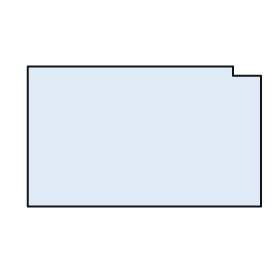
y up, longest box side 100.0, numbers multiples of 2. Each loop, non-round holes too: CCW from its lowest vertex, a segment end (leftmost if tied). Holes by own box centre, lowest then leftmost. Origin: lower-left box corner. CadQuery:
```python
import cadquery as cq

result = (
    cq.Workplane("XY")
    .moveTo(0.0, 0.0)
    .lineTo(100.0, 0.0)
    .lineTo(100.0, 56.0)
    .lineTo(88.0, 56.0)
    .lineTo(88.0, 60.0)
    .lineTo(0.0, 60.0)
    .close()
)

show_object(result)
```